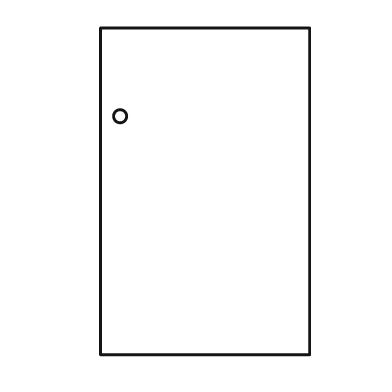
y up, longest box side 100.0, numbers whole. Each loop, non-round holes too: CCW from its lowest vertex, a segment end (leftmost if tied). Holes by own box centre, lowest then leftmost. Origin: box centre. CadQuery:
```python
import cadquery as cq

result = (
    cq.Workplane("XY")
    .moveTo(-32.0, -50.0)
    .lineTo(32.0, -50.0)
    .lineTo(32.0, 50.0)
    .lineTo(-32.0, 50.0)
    .close()
    .moveTo(-26.0, 23.0)
    .circle(2.0)
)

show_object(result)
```